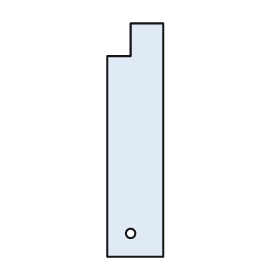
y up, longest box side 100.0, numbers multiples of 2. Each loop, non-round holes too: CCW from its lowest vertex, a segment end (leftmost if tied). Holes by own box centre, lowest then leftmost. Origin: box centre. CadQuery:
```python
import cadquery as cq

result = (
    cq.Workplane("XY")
    .moveTo(-12.0, -50.0)
    .lineTo(12.0, -50.0)
    .lineTo(12.0, 50.0)
    .lineTo(-2.0, 50.0)
    .lineTo(-2.0, 36.0)
    .lineTo(-12.0, 36.0)
    .close()
    .moveTo(-2.0, -40.0)
    .circle(2.0)
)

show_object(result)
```